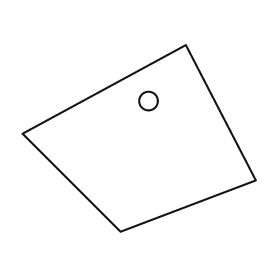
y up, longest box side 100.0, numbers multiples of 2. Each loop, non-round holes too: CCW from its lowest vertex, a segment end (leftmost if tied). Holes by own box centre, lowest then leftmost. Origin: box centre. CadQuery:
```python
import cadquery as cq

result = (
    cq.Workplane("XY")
    .moveTo(-8.0, -40.0)
    .lineTo(50.0, -18.0)
    .lineTo(20.0, 40.0)
    .lineTo(-50.0, 2.0)
    .close()
    .moveTo(4.0, 16.0)
    .circle(4.0)
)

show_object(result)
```